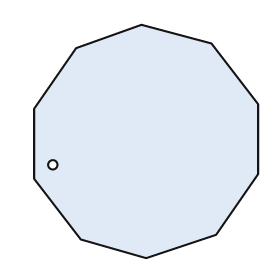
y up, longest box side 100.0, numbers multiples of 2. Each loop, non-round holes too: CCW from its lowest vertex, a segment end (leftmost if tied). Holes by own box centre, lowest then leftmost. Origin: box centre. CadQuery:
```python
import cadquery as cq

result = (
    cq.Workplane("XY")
    .moveTo(0.0, -50.0)
    .lineTo(30.0, -40.0)
    .lineTo(48.0, -14.0)
    .lineTo(48.0, 16.0)
    .lineTo(28.0, 42.0)
    .lineTo(-2.0, 50.0)
    .lineTo(-30.0, 40.0)
    .lineTo(-48.0, 14.0)
    .lineTo(-48.0, -16.0)
    .lineTo(-28.0, -42.0)
    .close()
    .moveTo(-40.0, -10.0)
    .circle(2.0)
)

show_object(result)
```